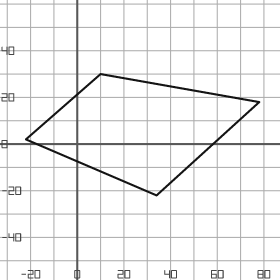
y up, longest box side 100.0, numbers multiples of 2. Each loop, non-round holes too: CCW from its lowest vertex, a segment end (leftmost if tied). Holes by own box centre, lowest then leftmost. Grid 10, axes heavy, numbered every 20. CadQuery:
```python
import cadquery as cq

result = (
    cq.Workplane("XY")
    .moveTo(34.0, -22.0)
    .lineTo(78.0, 18.0)
    .lineTo(10.0, 30.0)
    .lineTo(-22.0, 2.0)
    .close()
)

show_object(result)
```